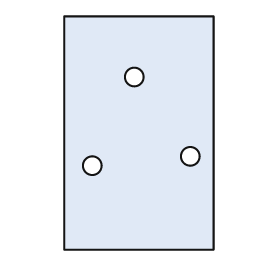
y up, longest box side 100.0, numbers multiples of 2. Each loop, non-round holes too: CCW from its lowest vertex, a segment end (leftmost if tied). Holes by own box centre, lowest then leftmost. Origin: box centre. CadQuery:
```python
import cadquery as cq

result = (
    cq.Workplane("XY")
    .moveTo(-32.0, -50.0)
    .lineTo(32.0, -50.0)
    .lineTo(32.0, 50.0)
    .lineTo(-32.0, 50.0)
    .close()
    .moveTo(-20.0, -14.0)
    .circle(4.0)
    .moveTo(22.0, -10.0)
    .circle(4.0)
    .moveTo(-2.0, 24.0)
    .circle(4.0)
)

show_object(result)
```